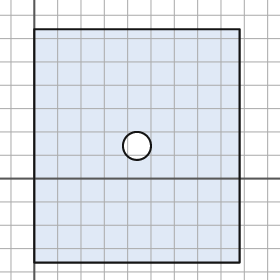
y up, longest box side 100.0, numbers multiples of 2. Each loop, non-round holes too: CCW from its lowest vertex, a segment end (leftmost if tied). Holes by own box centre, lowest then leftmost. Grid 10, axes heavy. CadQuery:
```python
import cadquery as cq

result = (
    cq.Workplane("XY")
    .moveTo(0.0, -36.0)
    .lineTo(88.0, -36.0)
    .lineTo(88.0, 64.0)
    .lineTo(0.0, 64.0)
    .close()
    .moveTo(44.0, 14.0)
    .circle(6.0)
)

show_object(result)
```